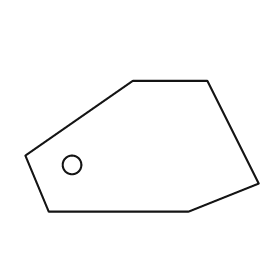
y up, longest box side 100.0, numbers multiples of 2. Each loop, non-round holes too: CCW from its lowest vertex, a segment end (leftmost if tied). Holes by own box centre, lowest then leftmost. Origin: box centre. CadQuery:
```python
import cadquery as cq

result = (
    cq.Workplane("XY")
    .moveTo(-40.0, -28.0)
    .lineTo(20.0, -28.0)
    .lineTo(50.0, -16.0)
    .lineTo(28.0, 28.0)
    .lineTo(-4.0, 28.0)
    .lineTo(-50.0, -4.0)
    .close()
    .moveTo(-30.0, -8.0)
    .circle(4.0)
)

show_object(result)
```